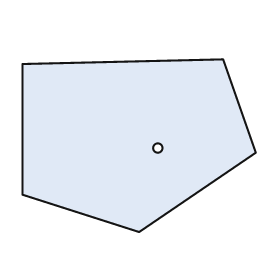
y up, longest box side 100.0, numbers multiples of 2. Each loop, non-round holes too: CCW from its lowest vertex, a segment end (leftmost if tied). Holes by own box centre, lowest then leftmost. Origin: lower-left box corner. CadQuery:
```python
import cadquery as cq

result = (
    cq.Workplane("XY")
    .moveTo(50.0, 0.0)
    .lineTo(100.0, 34.0)
    .lineTo(86.0, 74.0)
    .lineTo(0.0, 72.0)
    .lineTo(0.0, 16.0)
    .close()
    .moveTo(58.0, 36.0)
    .circle(2.0)
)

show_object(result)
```